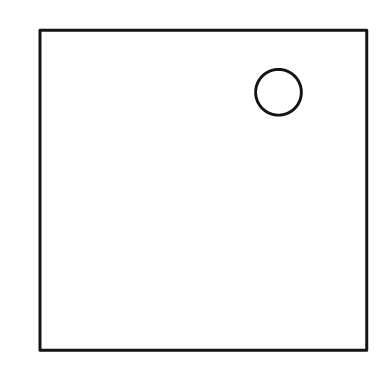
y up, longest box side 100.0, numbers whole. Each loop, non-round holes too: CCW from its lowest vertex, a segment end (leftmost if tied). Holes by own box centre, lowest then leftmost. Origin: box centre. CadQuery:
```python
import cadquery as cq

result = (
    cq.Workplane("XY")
    .moveTo(-50.0, -49.0)
    .lineTo(50.0, -49.0)
    .lineTo(50.0, 49.0)
    .lineTo(-50.0, 49.0)
    .close()
    .moveTo(23.0, 30.0)
    .circle(7.0)
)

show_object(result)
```